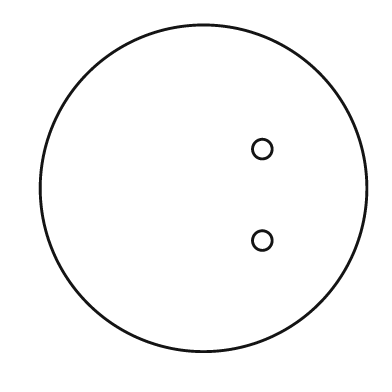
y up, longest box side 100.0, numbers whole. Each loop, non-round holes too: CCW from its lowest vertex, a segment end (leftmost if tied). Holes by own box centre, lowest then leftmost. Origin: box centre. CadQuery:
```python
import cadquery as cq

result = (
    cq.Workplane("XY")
    .moveTo(0.0, 0.0)
    .circle(50.0)
    .moveTo(18.0, -16.0)
    .circle(3.0)
    .moveTo(18.0, 12.0)
    .circle(3.0)
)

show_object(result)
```